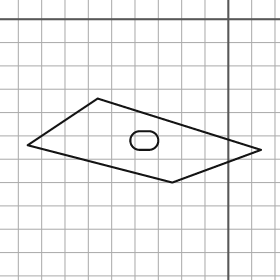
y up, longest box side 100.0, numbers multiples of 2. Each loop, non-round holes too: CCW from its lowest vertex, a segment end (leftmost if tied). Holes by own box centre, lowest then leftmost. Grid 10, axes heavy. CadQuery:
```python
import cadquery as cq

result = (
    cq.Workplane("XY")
    .moveTo(-24.0, -70.0)
    .lineTo(14.0, -56.0)
    .lineTo(-56.0, -34.0)
    .lineTo(-86.0, -54.0)
    .close()
    .moveTo(-38.0, -56.0)
    .lineTo(-34.0, -56.0)
    .threePointArc((-30.0, -52.0), (-34.0, -48.0))
    .lineTo(-38.0, -48.0)
    .threePointArc((-42.0, -52.0), (-38.0, -56.0))
    .close()
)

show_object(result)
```